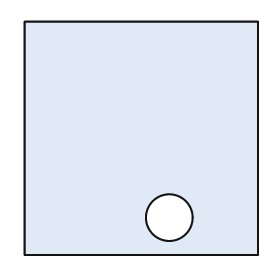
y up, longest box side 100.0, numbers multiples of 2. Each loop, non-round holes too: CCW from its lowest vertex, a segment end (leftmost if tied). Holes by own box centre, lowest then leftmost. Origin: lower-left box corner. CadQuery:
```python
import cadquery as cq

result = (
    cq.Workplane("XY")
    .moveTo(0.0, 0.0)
    .lineTo(100.0, 0.0)
    .lineTo(100.0, 100.0)
    .lineTo(0.0, 100.0)
    .close()
    .moveTo(62.0, 16.0)
    .circle(10.0)
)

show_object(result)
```